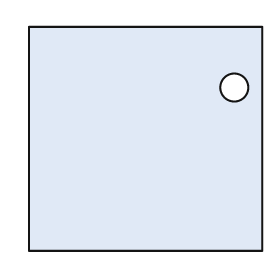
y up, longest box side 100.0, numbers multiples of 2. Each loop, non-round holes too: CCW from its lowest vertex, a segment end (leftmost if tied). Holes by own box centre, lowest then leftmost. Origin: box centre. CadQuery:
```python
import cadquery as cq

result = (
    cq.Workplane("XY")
    .moveTo(-50.0, -48.0)
    .lineTo(50.0, -48.0)
    .lineTo(50.0, 48.0)
    .lineTo(-50.0, 48.0)
    .close()
    .moveTo(38.0, 22.0)
    .circle(6.0)
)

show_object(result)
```